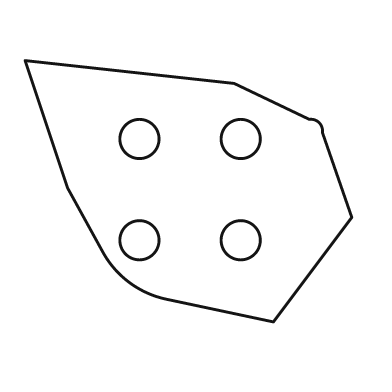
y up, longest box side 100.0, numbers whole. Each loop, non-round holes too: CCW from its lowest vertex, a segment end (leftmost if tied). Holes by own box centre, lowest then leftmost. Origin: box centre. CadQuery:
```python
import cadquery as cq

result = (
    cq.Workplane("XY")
    .moveTo(26.0, -40.0)
    .lineTo(50.0, -8.0)
    .lineTo(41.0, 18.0)
    .threePointArc((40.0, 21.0), (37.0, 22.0))
    .lineTo(14.0, 33.0)
    .lineTo(-50.0, 40.0)
    .lineTo(-37.0, 1.0)
    .lineTo(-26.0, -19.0)
    .threePointArc((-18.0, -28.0), (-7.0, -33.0))
    .close()
    .moveTo(-15.0, -15.0)
    .circle(6.0)
    .moveTo(16.0, -15.0)
    .circle(6.0)
    .moveTo(-15.0, 16.0)
    .circle(6.0)
    .moveTo(16.0, 16.0)
    .circle(6.0)
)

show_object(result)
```